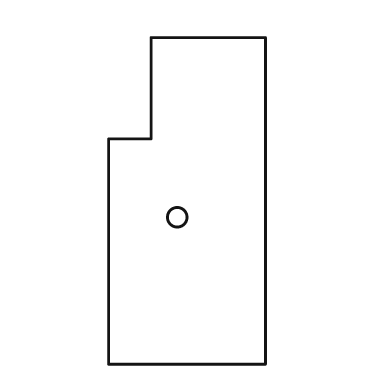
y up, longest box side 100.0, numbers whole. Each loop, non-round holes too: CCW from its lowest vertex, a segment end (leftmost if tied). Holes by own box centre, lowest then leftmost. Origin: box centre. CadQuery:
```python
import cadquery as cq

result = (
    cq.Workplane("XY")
    .moveTo(-24.0, -50.0)
    .lineTo(24.0, -50.0)
    .lineTo(24.0, 50.0)
    .lineTo(-11.0, 50.0)
    .lineTo(-11.0, 19.0)
    .lineTo(-24.0, 19.0)
    .close()
    .moveTo(-3.0, -5.0)
    .circle(3.0)
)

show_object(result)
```